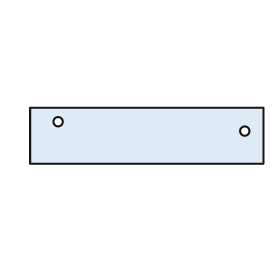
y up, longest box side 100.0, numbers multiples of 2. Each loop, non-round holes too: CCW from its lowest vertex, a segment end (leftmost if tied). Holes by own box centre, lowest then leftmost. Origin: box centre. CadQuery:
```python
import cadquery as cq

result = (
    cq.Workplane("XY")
    .moveTo(-50.0, -12.0)
    .lineTo(50.0, -12.0)
    .lineTo(50.0, 12.0)
    .lineTo(-50.0, 12.0)
    .close()
    .moveTo(42.0, 2.0)
    .circle(2.0)
    .moveTo(-38.0, 6.0)
    .circle(2.0)
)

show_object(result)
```